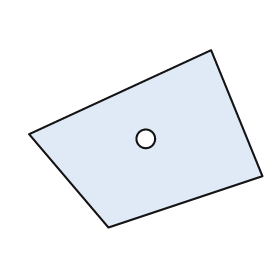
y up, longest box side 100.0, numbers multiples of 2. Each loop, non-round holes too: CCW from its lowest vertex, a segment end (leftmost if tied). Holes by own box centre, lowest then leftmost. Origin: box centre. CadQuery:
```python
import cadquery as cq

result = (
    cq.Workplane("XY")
    .moveTo(-16.0, -38.0)
    .lineTo(50.0, -16.0)
    .lineTo(28.0, 38.0)
    .lineTo(-50.0, 2.0)
    .close()
    .moveTo(0.0, 0.0)
    .circle(4.0)
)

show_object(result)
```